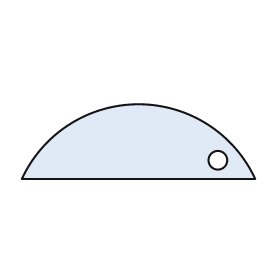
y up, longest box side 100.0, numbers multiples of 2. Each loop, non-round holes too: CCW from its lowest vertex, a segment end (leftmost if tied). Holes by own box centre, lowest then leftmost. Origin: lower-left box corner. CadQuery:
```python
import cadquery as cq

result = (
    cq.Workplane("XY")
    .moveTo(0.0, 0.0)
    .lineTo(100.0, 0.0)
    .threePointArc((50.0, 32.0), (0.0, 0.0))
    .close()
    .moveTo(84.0, 8.0)
    .circle(4.0)
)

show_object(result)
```